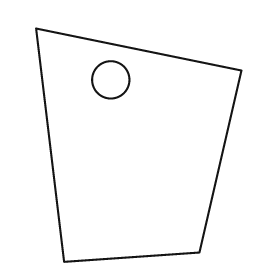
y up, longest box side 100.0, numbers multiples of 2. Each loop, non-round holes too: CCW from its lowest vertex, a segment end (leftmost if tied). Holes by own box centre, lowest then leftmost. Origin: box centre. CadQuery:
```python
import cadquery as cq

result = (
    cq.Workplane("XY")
    .moveTo(-32.0, -50.0)
    .lineTo(26.0, -46.0)
    .lineTo(44.0, 32.0)
    .lineTo(-44.0, 50.0)
    .close()
    .moveTo(-12.0, 28.0)
    .circle(8.0)
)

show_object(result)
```